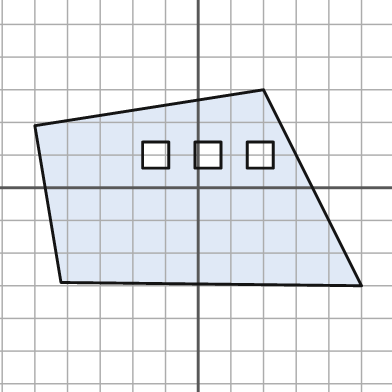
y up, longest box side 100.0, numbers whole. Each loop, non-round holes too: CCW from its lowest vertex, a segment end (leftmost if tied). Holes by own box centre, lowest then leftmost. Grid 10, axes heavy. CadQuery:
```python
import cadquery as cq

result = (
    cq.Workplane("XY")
    .moveTo(50.0, -30.0)
    .lineTo(20.0, 30.0)
    .lineTo(-50.0, 19.0)
    .lineTo(-42.0, -29.0)
    .close()
    .moveTo(-17.0, 6.0)
    .lineTo(-9.0, 6.0)
    .lineTo(-9.0, 14.0)
    .lineTo(-17.0, 14.0)
    .close()
    .moveTo(-1.0, 6.0)
    .lineTo(7.0, 6.0)
    .lineTo(7.0, 14.0)
    .lineTo(-1.0, 14.0)
    .close()
    .moveTo(15.0, 6.0)
    .lineTo(23.0, 6.0)
    .lineTo(23.0, 14.0)
    .lineTo(15.0, 14.0)
    .close()
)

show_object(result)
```